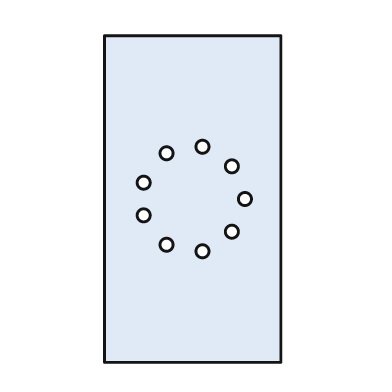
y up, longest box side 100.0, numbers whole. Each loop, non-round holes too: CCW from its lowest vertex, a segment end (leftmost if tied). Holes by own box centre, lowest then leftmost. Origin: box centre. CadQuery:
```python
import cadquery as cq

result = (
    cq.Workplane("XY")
    .moveTo(-27.0, -50.0)
    .lineTo(27.0, -50.0)
    .lineTo(27.0, 50.0)
    .lineTo(-27.0, 50.0)
    .close()
    .moveTo(3.0, -16.0)
    .circle(2.0)
    .moveTo(-8.0, -14.0)
    .circle(2.0)
    .moveTo(12.0, -10.0)
    .circle(2.0)
    .moveTo(-15.0, -5.0)
    .circle(2.0)
    .moveTo(16.0, 0.0)
    .circle(2.0)
    .moveTo(-15.0, 5.0)
    .circle(2.0)
    .moveTo(12.0, 10.0)
    .circle(2.0)
    .moveTo(-8.0, 14.0)
    .circle(2.0)
    .moveTo(3.0, 16.0)
    .circle(2.0)
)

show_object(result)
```